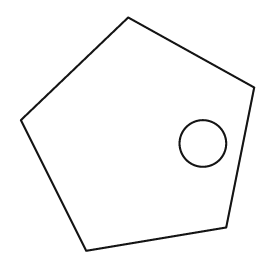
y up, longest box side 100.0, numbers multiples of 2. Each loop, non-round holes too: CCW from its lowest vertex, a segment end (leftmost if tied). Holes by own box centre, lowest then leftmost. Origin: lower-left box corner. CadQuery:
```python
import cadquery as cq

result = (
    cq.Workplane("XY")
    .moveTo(28.0, 0.0)
    .lineTo(88.0, 10.0)
    .lineTo(100.0, 70.0)
    .lineTo(46.0, 100.0)
    .lineTo(0.0, 56.0)
    .close()
    .moveTo(78.0, 46.0)
    .circle(10.0)
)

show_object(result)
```